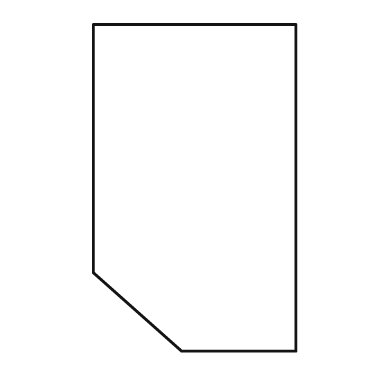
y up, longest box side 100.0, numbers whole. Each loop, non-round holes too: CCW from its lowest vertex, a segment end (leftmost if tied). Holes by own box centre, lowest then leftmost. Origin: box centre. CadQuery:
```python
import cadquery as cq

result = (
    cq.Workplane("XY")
    .moveTo(-4.0, -50.0)
    .lineTo(31.0, -50.0)
    .lineTo(31.0, 50.0)
    .lineTo(-31.0, 50.0)
    .lineTo(-31.0, -26.0)
    .close()
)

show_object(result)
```